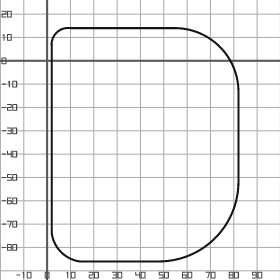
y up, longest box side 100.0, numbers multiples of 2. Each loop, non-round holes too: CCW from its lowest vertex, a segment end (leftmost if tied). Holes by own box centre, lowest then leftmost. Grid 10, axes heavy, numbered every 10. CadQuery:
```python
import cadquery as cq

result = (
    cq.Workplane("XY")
    .moveTo(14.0, -86.0)
    .lineTo(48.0, -86.0)
    .threePointArc((72.0, -76.0), (82.0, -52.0))
    .lineTo(82.0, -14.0)
    .threePointArc((74.0, 6.0), (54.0, 14.0))
    .lineTo(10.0, 14.0)
    .threePointArc((4.0, 12.0), (2.0, 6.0))
    .lineTo(2.0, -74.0)
    .threePointArc((6.0, -82.0), (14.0, -86.0))
    .close()
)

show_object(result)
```